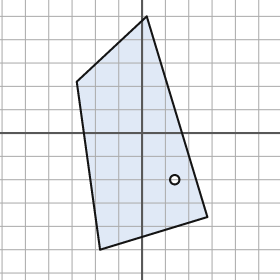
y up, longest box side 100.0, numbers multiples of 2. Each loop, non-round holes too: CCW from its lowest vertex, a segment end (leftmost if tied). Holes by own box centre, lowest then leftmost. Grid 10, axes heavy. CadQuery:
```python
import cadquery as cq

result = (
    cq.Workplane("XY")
    .moveTo(-18.0, -50.0)
    .lineTo(28.0, -36.0)
    .lineTo(2.0, 50.0)
    .lineTo(-28.0, 22.0)
    .close()
    .moveTo(14.0, -20.0)
    .circle(2.0)
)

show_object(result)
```